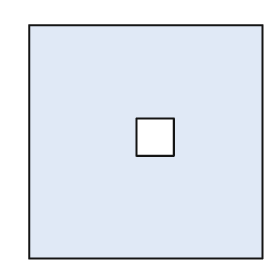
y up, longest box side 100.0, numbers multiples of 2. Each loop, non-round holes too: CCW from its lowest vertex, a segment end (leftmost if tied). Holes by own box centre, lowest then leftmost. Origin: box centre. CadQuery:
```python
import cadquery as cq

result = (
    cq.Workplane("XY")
    .moveTo(-50.0, -50.0)
    .lineTo(50.0, -50.0)
    .lineTo(50.0, 50.0)
    .lineTo(-50.0, 50.0)
    .close()
    .moveTo(-4.0, -6.0)
    .lineTo(12.0, -6.0)
    .lineTo(12.0, 10.0)
    .lineTo(-4.0, 10.0)
    .close()
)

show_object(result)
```